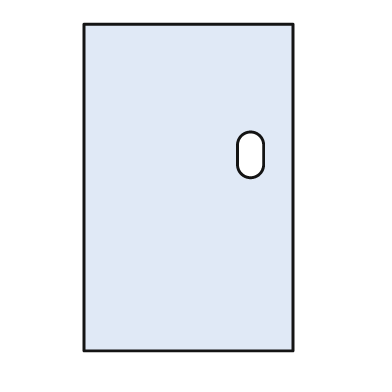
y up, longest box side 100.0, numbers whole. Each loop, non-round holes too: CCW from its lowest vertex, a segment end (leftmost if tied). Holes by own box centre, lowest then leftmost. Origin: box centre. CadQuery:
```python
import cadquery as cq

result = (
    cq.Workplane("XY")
    .moveTo(-32.0, -50.0)
    .lineTo(32.0, -50.0)
    .lineTo(32.0, 50.0)
    .lineTo(-32.0, 50.0)
    .close()
    .moveTo(15.0, 7.0)
    .threePointArc((19.0, 3.0), (23.0, 7.0))
    .lineTo(23.0, 13.0)
    .threePointArc((19.0, 17.0), (15.0, 13.0))
    .close()
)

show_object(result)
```